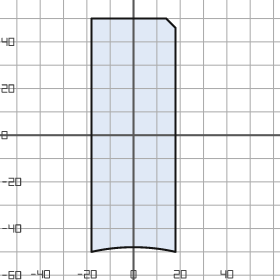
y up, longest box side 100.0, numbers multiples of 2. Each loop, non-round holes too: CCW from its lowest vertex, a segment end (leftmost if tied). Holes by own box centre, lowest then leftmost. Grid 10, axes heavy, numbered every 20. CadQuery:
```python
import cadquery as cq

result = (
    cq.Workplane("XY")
    .moveTo(-18.0, -50.0)
    .threePointArc((0.0, -48.0), (18.0, -50.0))
    .lineTo(18.0, 46.0)
    .lineTo(14.0, 50.0)
    .lineTo(-18.0, 50.0)
    .close()
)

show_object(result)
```